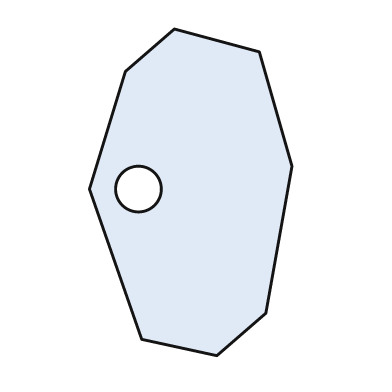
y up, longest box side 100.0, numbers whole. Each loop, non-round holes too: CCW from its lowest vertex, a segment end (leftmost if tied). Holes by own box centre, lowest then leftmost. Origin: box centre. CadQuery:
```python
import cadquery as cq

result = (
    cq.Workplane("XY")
    .moveTo(8.0, -50.0)
    .lineTo(23.0, -37.0)
    .lineTo(31.0, 8.0)
    .lineTo(21.0, 43.0)
    .lineTo(-5.0, 50.0)
    .lineTo(-20.0, 37.0)
    .lineTo(-31.0, 1.0)
    .lineTo(-15.0, -45.0)
    .close()
    .moveTo(-16.0, 1.0)
    .circle(7.0)
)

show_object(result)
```